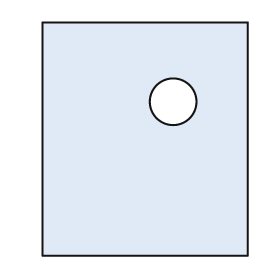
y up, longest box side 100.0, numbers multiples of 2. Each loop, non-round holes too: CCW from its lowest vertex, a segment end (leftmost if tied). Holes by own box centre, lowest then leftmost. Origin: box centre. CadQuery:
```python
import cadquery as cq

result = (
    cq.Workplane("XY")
    .moveTo(-44.0, -50.0)
    .lineTo(44.0, -50.0)
    .lineTo(44.0, 50.0)
    .lineTo(-44.0, 50.0)
    .close()
    .moveTo(12.0, 16.0)
    .circle(10.0)
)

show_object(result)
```